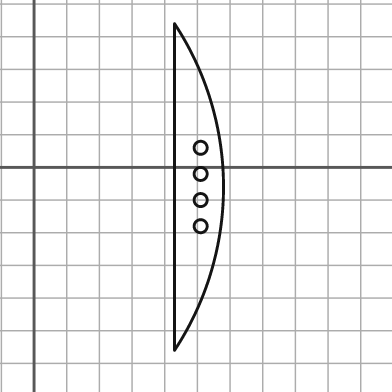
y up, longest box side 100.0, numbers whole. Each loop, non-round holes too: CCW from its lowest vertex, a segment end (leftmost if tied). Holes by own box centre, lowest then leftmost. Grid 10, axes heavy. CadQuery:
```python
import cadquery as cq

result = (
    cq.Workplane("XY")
    .moveTo(43.0, -56.0)
    .threePointArc((58.0, -6.0), (43.0, 44.0))
    .close()
    .moveTo(51.0, -18.0)
    .circle(2.0)
    .moveTo(51.0, -10.0)
    .circle(2.0)
    .moveTo(51.0, -2.0)
    .circle(2.0)
    .moveTo(51.0, 6.0)
    .circle(2.0)
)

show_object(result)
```